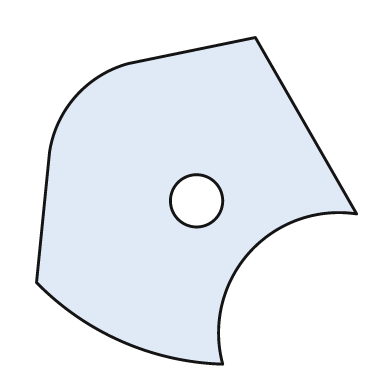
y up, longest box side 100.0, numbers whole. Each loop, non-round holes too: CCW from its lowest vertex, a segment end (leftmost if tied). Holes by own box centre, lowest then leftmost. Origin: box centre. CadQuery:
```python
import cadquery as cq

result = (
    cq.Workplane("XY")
    .moveTo(8.0, -50.0)
    .threePointArc((16.0, -16.0), (49.0, -4.0))
    .lineTo(18.0, 50.0)
    .lineTo(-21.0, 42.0)
    .threePointArc((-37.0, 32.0), (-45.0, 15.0))
    .lineTo(-49.0, -25.0)
    .threePointArc((-23.0, -43.0), (8.0, -50.0))
    .close()
    .moveTo(0.0, 0.0)
    .circle(8.0)
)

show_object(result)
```